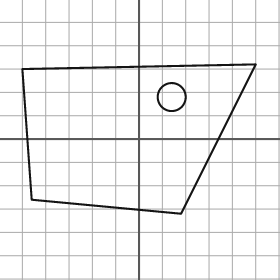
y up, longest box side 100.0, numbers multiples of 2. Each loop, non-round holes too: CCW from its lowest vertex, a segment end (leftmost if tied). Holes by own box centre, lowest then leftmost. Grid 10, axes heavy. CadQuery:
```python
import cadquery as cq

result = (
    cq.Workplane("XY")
    .moveTo(18.0, -32.0)
    .lineTo(50.0, 32.0)
    .lineTo(-50.0, 30.0)
    .lineTo(-46.0, -26.0)
    .close()
    .moveTo(14.0, 18.0)
    .circle(6.0)
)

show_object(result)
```